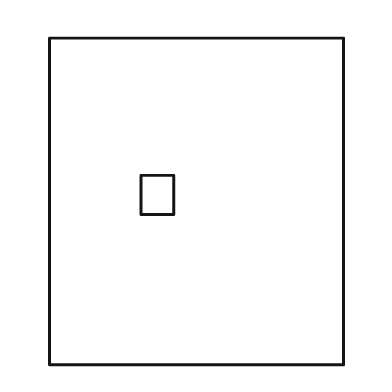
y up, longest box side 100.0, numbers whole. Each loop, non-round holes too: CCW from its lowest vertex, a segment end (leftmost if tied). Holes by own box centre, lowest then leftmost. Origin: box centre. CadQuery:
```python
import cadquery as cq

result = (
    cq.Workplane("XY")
    .moveTo(-45.0, -50.0)
    .lineTo(45.0, -50.0)
    .lineTo(45.0, 50.0)
    .lineTo(-45.0, 50.0)
    .close()
    .moveTo(-17.0, -4.0)
    .lineTo(-7.0, -4.0)
    .lineTo(-7.0, 8.0)
    .lineTo(-17.0, 8.0)
    .close()
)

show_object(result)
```